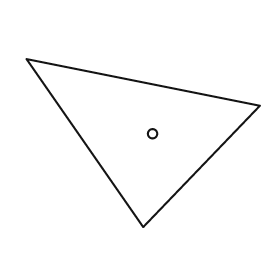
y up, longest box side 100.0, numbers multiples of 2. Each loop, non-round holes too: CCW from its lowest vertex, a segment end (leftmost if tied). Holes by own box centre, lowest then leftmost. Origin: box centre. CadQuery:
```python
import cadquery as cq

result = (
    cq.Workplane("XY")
    .moveTo(0.0, -36.0)
    .lineTo(50.0, 16.0)
    .lineTo(-50.0, 36.0)
    .close()
    .moveTo(4.0, 4.0)
    .circle(2.0)
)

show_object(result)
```